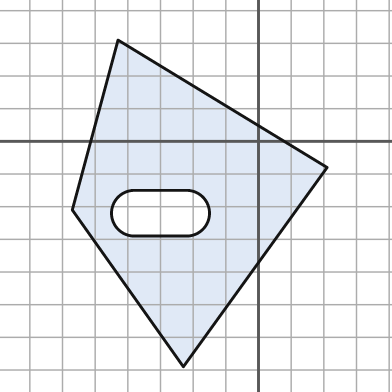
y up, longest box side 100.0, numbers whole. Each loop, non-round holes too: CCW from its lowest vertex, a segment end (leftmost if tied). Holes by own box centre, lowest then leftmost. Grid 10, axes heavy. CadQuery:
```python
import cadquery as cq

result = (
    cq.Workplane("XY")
    .moveTo(-23.0, -69.0)
    .lineTo(21.0, -8.0)
    .lineTo(-43.0, 31.0)
    .lineTo(-57.0, -21.0)
    .close()
    .moveTo(-38.0, -29.0)
    .lineTo(-22.0, -29.0)
    .threePointArc((-15.0, -22.0), (-22.0, -15.0))
    .lineTo(-38.0, -15.0)
    .threePointArc((-45.0, -22.0), (-38.0, -29.0))
    .close()
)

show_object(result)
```